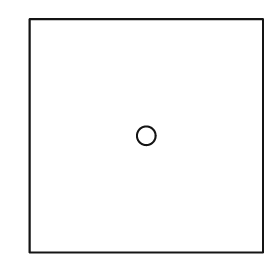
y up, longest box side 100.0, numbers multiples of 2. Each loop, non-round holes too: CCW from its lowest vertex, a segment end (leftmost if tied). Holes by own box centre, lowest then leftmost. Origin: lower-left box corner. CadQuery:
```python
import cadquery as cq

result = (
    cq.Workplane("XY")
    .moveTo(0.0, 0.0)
    .lineTo(100.0, 0.0)
    .lineTo(100.0, 100.0)
    .lineTo(0.0, 100.0)
    .close()
    .moveTo(50.0, 50.0)
    .circle(4.0)
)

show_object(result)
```